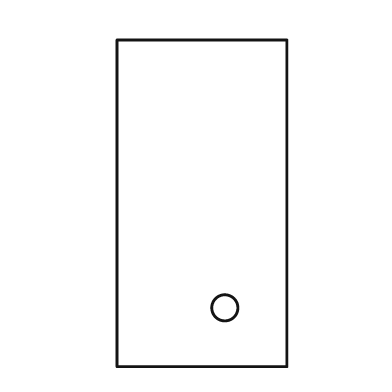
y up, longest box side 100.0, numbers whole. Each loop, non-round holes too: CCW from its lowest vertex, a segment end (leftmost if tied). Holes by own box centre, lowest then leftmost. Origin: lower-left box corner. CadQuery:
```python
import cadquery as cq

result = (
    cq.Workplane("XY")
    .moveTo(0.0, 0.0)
    .lineTo(52.0, 0.0)
    .lineTo(52.0, 100.0)
    .lineTo(0.0, 100.0)
    .close()
    .moveTo(33.0, 18.0)
    .circle(4.0)
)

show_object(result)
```